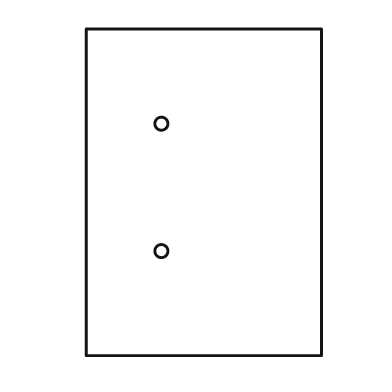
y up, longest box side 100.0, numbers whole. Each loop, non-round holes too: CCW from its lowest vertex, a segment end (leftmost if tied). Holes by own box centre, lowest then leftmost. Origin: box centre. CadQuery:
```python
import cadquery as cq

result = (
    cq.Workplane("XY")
    .moveTo(-36.0, -50.0)
    .lineTo(36.0, -50.0)
    .lineTo(36.0, 50.0)
    .lineTo(-36.0, 50.0)
    .close()
    .moveTo(-13.0, -18.0)
    .circle(2.0)
    .moveTo(-13.0, 21.0)
    .circle(2.0)
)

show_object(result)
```